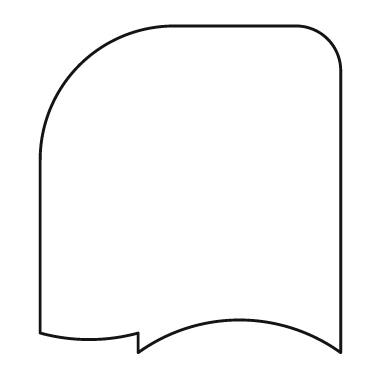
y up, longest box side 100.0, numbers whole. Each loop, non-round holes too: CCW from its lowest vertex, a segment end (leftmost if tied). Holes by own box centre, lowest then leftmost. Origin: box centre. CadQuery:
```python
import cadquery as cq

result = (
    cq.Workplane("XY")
    .moveTo(-16.0, -50.0)
    .threePointArc((15.0, -40.0), (46.0, -50.0))
    .lineTo(46.0, 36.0)
    .threePointArc((42.0, 46.0), (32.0, 50.0))
    .lineTo(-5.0, 50.0)
    .threePointArc((-34.0, 38.0), (-46.0, 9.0))
    .lineTo(-46.0, -44.0)
    .threePointArc((-31.0, -46.0), (-16.0, -44.0))
    .close()
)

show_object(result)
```